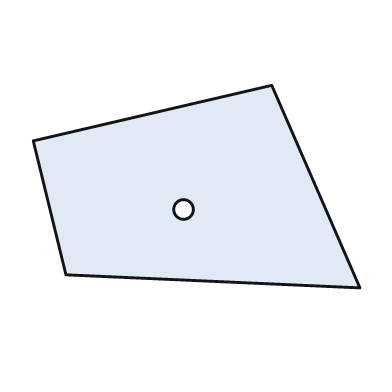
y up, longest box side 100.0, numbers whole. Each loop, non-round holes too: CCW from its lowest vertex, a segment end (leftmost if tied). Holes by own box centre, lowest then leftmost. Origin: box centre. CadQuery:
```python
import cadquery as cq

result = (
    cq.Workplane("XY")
    .moveTo(50.0, -31.0)
    .lineTo(23.0, 31.0)
    .lineTo(-50.0, 14.0)
    .lineTo(-40.0, -27.0)
    .close()
    .moveTo(-4.0, -7.0)
    .circle(3.0)
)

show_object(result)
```